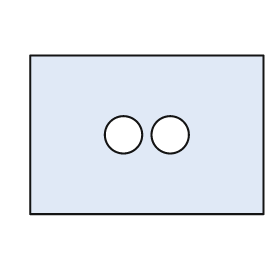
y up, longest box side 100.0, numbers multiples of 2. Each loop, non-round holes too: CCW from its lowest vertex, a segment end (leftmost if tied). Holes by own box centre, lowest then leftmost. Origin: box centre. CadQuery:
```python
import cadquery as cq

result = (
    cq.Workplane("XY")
    .moveTo(-50.0, -34.0)
    .lineTo(50.0, -34.0)
    .lineTo(50.0, 34.0)
    .lineTo(-50.0, 34.0)
    .close()
    .moveTo(-10.0, 0.0)
    .circle(8.0)
    .moveTo(10.0, 0.0)
    .circle(8.0)
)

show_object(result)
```